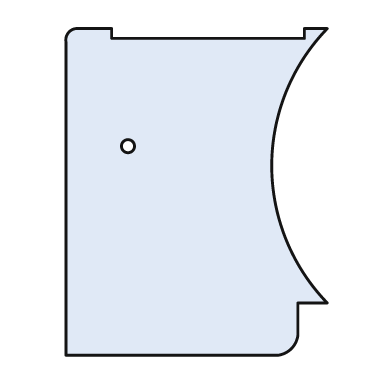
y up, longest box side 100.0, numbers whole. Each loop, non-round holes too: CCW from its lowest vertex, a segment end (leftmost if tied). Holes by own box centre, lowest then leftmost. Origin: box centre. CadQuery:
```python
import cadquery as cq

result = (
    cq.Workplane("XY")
    .moveTo(-40.0, -50.0)
    .lineTo(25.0, -50.0)
    .threePointArc((29.0, -48.0), (31.0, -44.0))
    .lineTo(31.0, -34.0)
    .lineTo(40.0, -34.0)
    .threePointArc((23.0, 8.0), (40.0, 50.0))
    .lineTo(33.0, 50.0)
    .lineTo(33.0, 47.0)
    .lineTo(-26.0, 47.0)
    .lineTo(-26.0, 50.0)
    .lineTo(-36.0, 50.0)
    .threePointArc((-39.0, 49.0), (-40.0, 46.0))
    .close()
    .moveTo(-21.0, 14.0)
    .circle(2.0)
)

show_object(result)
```